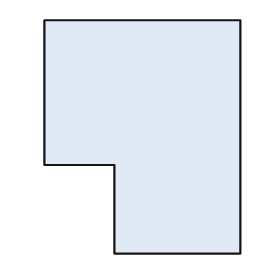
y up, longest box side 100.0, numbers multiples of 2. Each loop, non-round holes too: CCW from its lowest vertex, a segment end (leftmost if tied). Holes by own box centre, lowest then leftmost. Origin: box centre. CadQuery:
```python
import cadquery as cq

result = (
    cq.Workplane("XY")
    .moveTo(-12.0, -50.0)
    .lineTo(42.0, -50.0)
    .lineTo(42.0, 50.0)
    .lineTo(-42.0, 50.0)
    .lineTo(-42.0, -12.0)
    .lineTo(-12.0, -12.0)
    .close()
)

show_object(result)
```